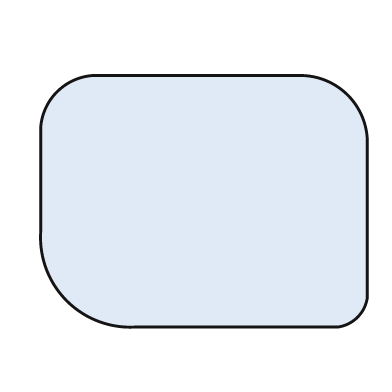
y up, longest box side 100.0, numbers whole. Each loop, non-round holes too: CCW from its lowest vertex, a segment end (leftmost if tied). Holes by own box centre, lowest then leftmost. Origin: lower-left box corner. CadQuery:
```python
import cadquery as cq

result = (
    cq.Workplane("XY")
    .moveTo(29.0, 0.0)
    .lineTo(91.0, 0.0)
    .threePointArc((97.0, 3.0), (100.0, 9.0))
    .lineTo(100.0, 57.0)
    .threePointArc((94.0, 71.0), (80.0, 77.0))
    .lineTo(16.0, 77.0)
    .threePointArc((5.0, 72.0), (0.0, 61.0))
    .lineTo(0.0, 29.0)
    .threePointArc((8.0, 8.0), (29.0, 0.0))
    .close()
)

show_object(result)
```